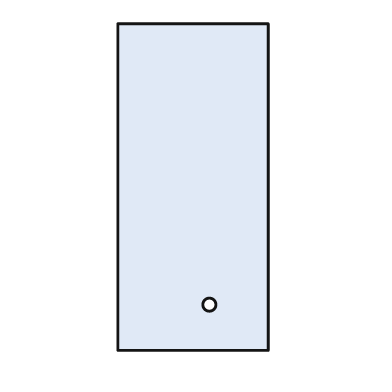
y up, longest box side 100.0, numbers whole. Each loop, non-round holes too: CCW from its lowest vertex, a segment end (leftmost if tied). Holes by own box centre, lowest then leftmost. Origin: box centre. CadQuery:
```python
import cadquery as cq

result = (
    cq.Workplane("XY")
    .moveTo(-23.0, -50.0)
    .lineTo(23.0, -50.0)
    .lineTo(23.0, 50.0)
    .lineTo(-23.0, 50.0)
    .close()
    .moveTo(5.0, -36.0)
    .circle(2.0)
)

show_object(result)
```